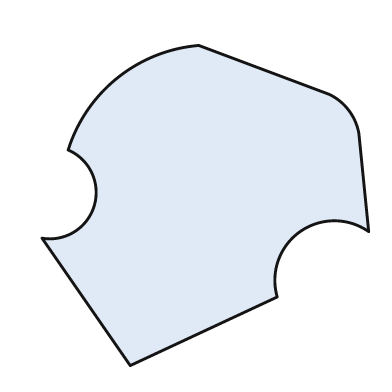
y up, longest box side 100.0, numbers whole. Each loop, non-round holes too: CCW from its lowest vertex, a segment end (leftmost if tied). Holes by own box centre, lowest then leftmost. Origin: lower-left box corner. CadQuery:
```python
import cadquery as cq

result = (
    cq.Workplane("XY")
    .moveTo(27.0, 0.0)
    .lineTo(72.0, 21.0)
    .threePointArc((79.0, 41.0), (100.0, 41.0))
    .lineTo(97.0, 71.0)
    .threePointArc((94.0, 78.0), (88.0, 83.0))
    .lineTo(48.0, 98.0)
    .threePointArc((23.0, 88.0), (8.0, 66.0))
    .threePointArc((16.0, 49.0), (0.0, 39.0))
    .close()
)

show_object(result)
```